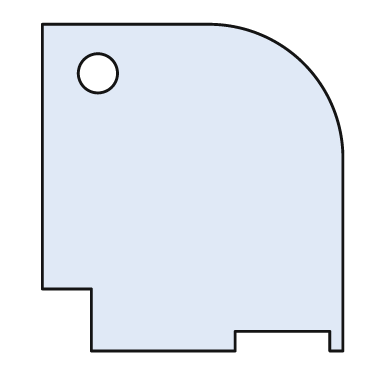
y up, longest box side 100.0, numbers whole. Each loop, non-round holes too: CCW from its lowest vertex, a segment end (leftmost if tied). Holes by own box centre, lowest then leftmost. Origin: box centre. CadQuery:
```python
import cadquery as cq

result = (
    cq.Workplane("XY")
    .moveTo(-31.0, -50.0)
    .lineTo(13.0, -50.0)
    .lineTo(13.0, -44.0)
    .lineTo(42.0, -44.0)
    .lineTo(42.0, -50.0)
    .lineTo(46.0, -50.0)
    .lineTo(46.0, 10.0)
    .threePointArc((34.0, 38.0), (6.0, 50.0))
    .lineTo(-46.0, 50.0)
    .lineTo(-46.0, -31.0)
    .lineTo(-31.0, -31.0)
    .close()
    .moveTo(-29.0, 35.0)
    .circle(6.0)
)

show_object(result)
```